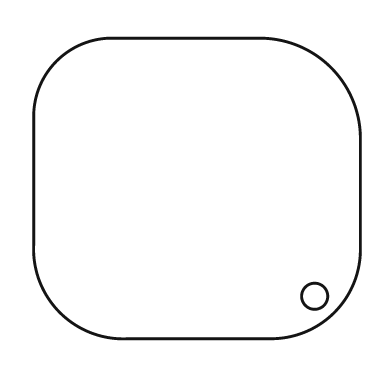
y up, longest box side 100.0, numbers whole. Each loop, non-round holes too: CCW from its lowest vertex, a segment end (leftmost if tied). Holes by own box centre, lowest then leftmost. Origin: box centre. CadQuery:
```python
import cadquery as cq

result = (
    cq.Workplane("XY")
    .moveTo(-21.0, -46.0)
    .lineTo(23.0, -46.0)
    .threePointArc((42.0, -38.0), (50.0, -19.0))
    .lineTo(50.0, 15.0)
    .threePointArc((41.0, 37.0), (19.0, 46.0))
    .lineTo(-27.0, 46.0)
    .threePointArc((-43.0, 39.0), (-50.0, 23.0))
    .lineTo(-50.0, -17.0)
    .threePointArc((-42.0, -38.0), (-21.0, -46.0))
    .close()
    .moveTo(36.0, -33.0)
    .circle(4.0)
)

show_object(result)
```